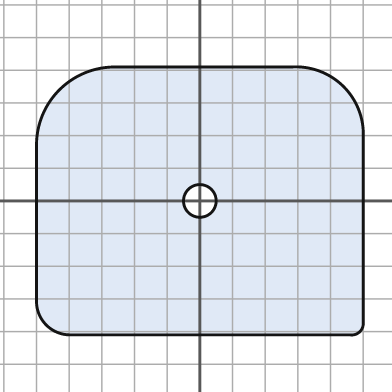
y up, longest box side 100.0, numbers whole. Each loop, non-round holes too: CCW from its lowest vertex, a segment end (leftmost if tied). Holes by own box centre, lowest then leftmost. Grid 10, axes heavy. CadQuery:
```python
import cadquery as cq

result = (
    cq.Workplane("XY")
    .moveTo(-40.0, -41.0)
    .lineTo(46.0, -41.0)
    .threePointArc((49.0, -40.0), (50.0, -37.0))
    .lineTo(50.0, 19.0)
    .threePointArc((44.0, 35.0), (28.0, 41.0))
    .lineTo(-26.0, 41.0)
    .threePointArc((-43.0, 34.0), (-50.0, 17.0))
    .lineTo(-50.0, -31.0)
    .threePointArc((-47.0, -38.0), (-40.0, -41.0))
    .close()
    .moveTo(0.0, 0.0)
    .circle(5.0)
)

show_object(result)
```